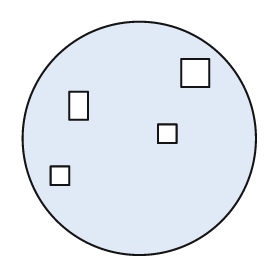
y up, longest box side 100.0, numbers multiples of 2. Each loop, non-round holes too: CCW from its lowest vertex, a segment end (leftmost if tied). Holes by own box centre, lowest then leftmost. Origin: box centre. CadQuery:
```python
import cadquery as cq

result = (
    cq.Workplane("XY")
    .moveTo(0.0, 0.0)
    .circle(50.0)
    .moveTo(-38.0, -20.0)
    .lineTo(-30.0, -20.0)
    .lineTo(-30.0, -12.0)
    .lineTo(-38.0, -12.0)
    .close()
    .moveTo(8.0, -2.0)
    .lineTo(16.0, -2.0)
    .lineTo(16.0, 6.0)
    .lineTo(8.0, 6.0)
    .close()
    .moveTo(-30.0, 8.0)
    .lineTo(-22.0, 8.0)
    .lineTo(-22.0, 20.0)
    .lineTo(-30.0, 20.0)
    .close()
    .moveTo(18.0, 22.0)
    .lineTo(30.0, 22.0)
    .lineTo(30.0, 34.0)
    .lineTo(18.0, 34.0)
    .close()
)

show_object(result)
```